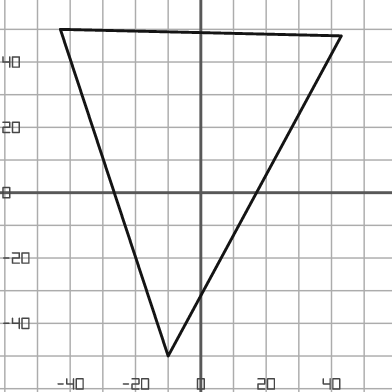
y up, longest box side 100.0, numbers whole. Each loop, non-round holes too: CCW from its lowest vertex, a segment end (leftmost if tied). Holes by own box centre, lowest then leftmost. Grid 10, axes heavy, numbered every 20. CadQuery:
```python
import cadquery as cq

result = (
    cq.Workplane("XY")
    .moveTo(-10.0, -50.0)
    .lineTo(43.0, 48.0)
    .lineTo(-43.0, 50.0)
    .close()
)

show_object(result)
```